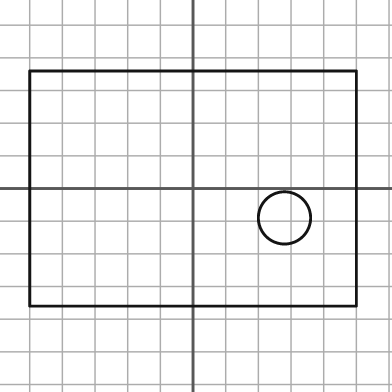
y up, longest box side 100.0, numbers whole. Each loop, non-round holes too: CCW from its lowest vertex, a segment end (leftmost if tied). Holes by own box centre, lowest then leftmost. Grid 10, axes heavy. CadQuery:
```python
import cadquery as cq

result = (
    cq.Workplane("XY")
    .moveTo(-50.0, -36.0)
    .lineTo(50.0, -36.0)
    .lineTo(50.0, 36.0)
    .lineTo(-50.0, 36.0)
    .close()
    .moveTo(28.0, -9.0)
    .circle(8.0)
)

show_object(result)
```